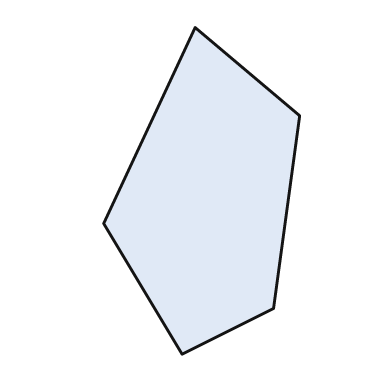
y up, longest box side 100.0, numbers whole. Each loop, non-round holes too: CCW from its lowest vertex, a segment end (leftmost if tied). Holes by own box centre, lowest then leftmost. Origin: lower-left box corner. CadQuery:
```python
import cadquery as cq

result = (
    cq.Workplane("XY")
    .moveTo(24.0, 0.0)
    .lineTo(52.0, 14.0)
    .lineTo(60.0, 73.0)
    .lineTo(28.0, 100.0)
    .lineTo(0.0, 40.0)
    .close()
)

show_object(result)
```